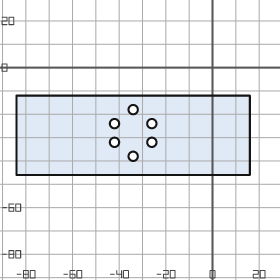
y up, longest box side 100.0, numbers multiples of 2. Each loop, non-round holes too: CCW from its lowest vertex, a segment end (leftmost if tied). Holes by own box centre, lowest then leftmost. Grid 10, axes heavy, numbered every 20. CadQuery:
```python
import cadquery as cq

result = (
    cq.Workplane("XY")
    .moveTo(-84.0, -46.0)
    .lineTo(16.0, -46.0)
    .lineTo(16.0, -12.0)
    .lineTo(-84.0, -12.0)
    .close()
    .moveTo(-34.0, -38.0)
    .circle(2.0)
    .moveTo(-42.0, -32.0)
    .circle(2.0)
    .moveTo(-26.0, -32.0)
    .circle(2.0)
    .moveTo(-42.0, -24.0)
    .circle(2.0)
    .moveTo(-26.0, -24.0)
    .circle(2.0)
    .moveTo(-34.0, -18.0)
    .circle(2.0)
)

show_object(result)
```